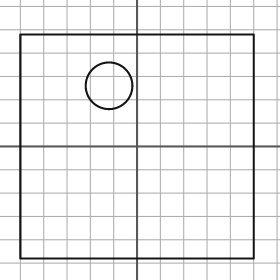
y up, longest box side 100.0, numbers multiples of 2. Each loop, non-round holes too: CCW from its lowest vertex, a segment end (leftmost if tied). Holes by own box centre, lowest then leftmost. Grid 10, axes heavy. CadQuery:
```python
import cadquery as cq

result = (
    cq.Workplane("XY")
    .moveTo(-50.0, -48.0)
    .lineTo(50.0, -48.0)
    .lineTo(50.0, 48.0)
    .lineTo(-50.0, 48.0)
    .close()
    .moveTo(-12.0, 26.0)
    .circle(10.0)
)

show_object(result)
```